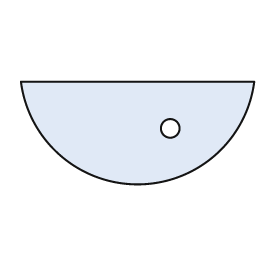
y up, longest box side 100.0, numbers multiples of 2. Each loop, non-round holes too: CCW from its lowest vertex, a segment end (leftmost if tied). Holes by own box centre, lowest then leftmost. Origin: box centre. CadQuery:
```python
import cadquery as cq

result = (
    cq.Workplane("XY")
    .moveTo(-50.0, 22.0)
    .threePointArc((0.0, -22.0), (50.0, 22.0))
    .close()
    .moveTo(14.0, 2.0)
    .circle(4.0)
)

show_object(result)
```